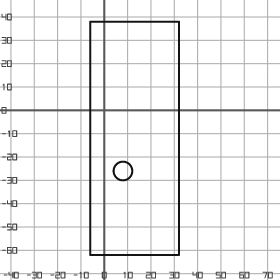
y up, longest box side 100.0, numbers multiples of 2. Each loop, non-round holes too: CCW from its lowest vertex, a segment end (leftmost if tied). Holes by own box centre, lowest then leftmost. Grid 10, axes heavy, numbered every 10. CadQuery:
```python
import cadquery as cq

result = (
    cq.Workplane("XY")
    .moveTo(-6.0, -62.0)
    .lineTo(32.0, -62.0)
    .lineTo(32.0, 38.0)
    .lineTo(-6.0, 38.0)
    .close()
    .moveTo(8.0, -26.0)
    .circle(4.0)
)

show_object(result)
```